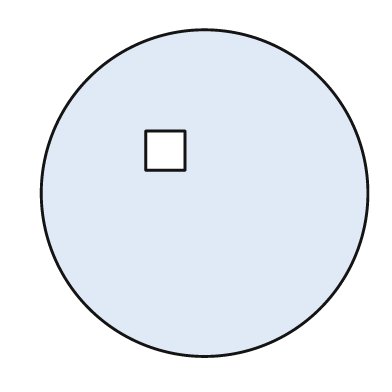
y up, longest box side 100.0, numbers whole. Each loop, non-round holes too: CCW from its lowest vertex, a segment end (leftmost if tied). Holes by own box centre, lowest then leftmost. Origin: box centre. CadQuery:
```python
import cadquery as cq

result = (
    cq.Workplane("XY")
    .moveTo(0.0, 0.0)
    .circle(50.0)
    .moveTo(-18.0, 7.0)
    .lineTo(-6.0, 7.0)
    .lineTo(-6.0, 19.0)
    .lineTo(-18.0, 19.0)
    .close()
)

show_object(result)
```